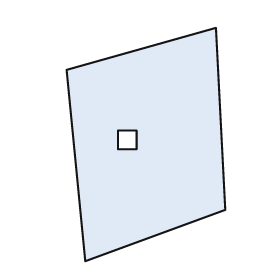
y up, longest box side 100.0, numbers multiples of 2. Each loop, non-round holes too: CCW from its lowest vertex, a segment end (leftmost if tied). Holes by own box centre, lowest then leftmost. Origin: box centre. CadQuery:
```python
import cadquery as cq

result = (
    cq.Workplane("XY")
    .moveTo(-26.0, -50.0)
    .lineTo(34.0, -28.0)
    .lineTo(30.0, 50.0)
    .lineTo(-34.0, 32.0)
    .close()
    .moveTo(-12.0, -2.0)
    .lineTo(-4.0, -2.0)
    .lineTo(-4.0, 6.0)
    .lineTo(-12.0, 6.0)
    .close()
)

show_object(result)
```